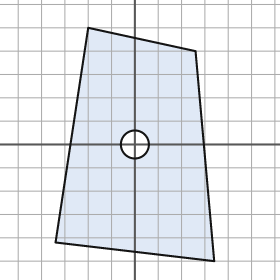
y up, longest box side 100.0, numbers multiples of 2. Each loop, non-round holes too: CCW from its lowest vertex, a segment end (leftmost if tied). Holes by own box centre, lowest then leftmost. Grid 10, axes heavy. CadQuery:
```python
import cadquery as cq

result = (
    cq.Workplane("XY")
    .moveTo(34.0, -50.0)
    .lineTo(26.0, 40.0)
    .lineTo(-20.0, 50.0)
    .lineTo(-34.0, -42.0)
    .close()
    .moveTo(0.0, 0.0)
    .circle(6.0)
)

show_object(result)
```